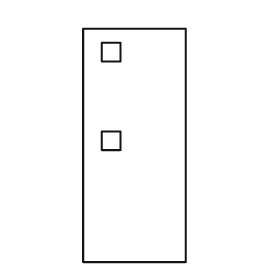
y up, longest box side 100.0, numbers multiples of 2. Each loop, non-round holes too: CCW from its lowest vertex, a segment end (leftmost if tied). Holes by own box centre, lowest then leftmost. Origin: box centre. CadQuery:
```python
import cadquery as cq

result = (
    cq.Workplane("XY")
    .moveTo(-22.0, -50.0)
    .lineTo(22.0, -50.0)
    .lineTo(22.0, 50.0)
    .lineTo(-22.0, 50.0)
    .close()
    .moveTo(-14.0, -2.0)
    .lineTo(-6.0, -2.0)
    .lineTo(-6.0, 6.0)
    .lineTo(-14.0, 6.0)
    .close()
    .moveTo(-14.0, 36.0)
    .lineTo(-6.0, 36.0)
    .lineTo(-6.0, 44.0)
    .lineTo(-14.0, 44.0)
    .close()
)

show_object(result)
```